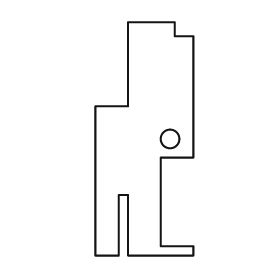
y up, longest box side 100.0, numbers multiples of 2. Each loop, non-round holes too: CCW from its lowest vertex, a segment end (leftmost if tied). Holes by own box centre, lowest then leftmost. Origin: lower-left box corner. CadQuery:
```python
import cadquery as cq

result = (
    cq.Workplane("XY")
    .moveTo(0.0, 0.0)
    .lineTo(10.0, 0.0)
    .lineTo(10.0, 26.0)
    .lineTo(14.0, 26.0)
    .lineTo(14.0, 0.0)
    .lineTo(42.0, 0.0)
    .lineTo(42.0, 4.0)
    .lineTo(28.0, 4.0)
    .lineTo(28.0, 42.0)
    .lineTo(42.0, 42.0)
    .lineTo(42.0, 94.0)
    .lineTo(34.0, 94.0)
    .lineTo(34.0, 100.0)
    .lineTo(14.0, 100.0)
    .lineTo(14.0, 64.0)
    .lineTo(0.0, 64.0)
    .close()
    .moveTo(32.0, 50.0)
    .circle(4.0)
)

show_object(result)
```